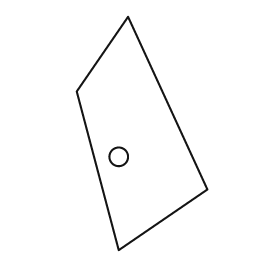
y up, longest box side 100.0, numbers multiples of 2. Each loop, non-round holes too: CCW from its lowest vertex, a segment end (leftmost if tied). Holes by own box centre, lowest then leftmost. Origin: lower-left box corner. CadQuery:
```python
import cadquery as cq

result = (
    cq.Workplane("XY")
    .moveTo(18.0, 0.0)
    .lineTo(56.0, 26.0)
    .lineTo(22.0, 100.0)
    .lineTo(0.0, 68.0)
    .close()
    .moveTo(18.0, 40.0)
    .circle(4.0)
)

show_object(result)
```